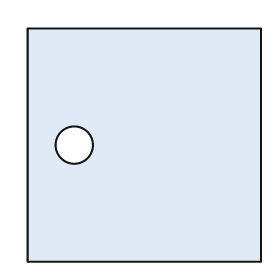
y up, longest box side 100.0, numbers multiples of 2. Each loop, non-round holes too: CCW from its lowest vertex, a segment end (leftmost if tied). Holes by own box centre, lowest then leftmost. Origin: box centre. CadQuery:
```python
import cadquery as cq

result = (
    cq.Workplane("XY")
    .moveTo(-50.0, -50.0)
    .lineTo(50.0, -50.0)
    .lineTo(50.0, 50.0)
    .lineTo(-50.0, 50.0)
    .close()
    .moveTo(-30.0, 0.0)
    .circle(8.0)
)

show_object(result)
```